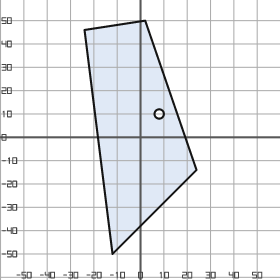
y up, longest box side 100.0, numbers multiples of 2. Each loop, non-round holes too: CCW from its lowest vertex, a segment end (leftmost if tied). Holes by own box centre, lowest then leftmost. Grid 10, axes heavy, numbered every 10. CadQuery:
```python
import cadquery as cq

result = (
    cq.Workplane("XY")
    .moveTo(-12.0, -50.0)
    .lineTo(24.0, -14.0)
    .lineTo(2.0, 50.0)
    .lineTo(-24.0, 46.0)
    .close()
    .moveTo(8.0, 10.0)
    .circle(2.0)
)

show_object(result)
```